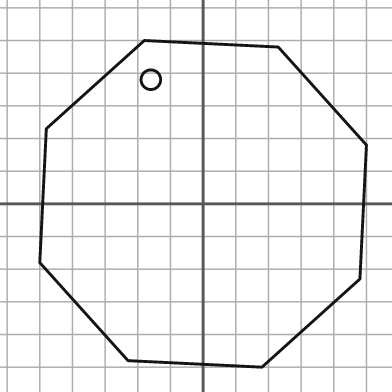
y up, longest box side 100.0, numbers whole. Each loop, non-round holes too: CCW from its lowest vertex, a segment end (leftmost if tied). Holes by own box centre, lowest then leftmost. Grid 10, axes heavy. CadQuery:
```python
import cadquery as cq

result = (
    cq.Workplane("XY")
    .moveTo(18.0, -50.0)
    .lineTo(48.0, -23.0)
    .lineTo(50.0, 18.0)
    .lineTo(23.0, 48.0)
    .lineTo(-18.0, 50.0)
    .lineTo(-48.0, 23.0)
    .lineTo(-50.0, -18.0)
    .lineTo(-23.0, -48.0)
    .close()
    .moveTo(-16.0, 38.0)
    .circle(3.0)
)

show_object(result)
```